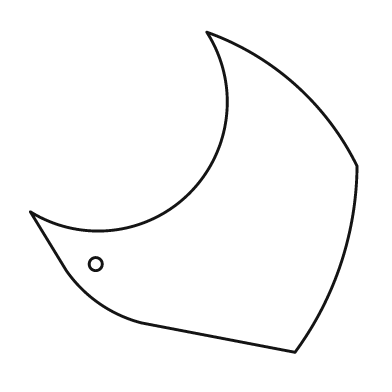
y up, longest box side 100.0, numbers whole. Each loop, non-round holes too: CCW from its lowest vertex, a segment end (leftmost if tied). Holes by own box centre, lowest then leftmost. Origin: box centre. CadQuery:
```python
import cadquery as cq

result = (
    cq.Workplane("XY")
    .moveTo(31.0, -49.0)
    .threePointArc((45.0, -22.0), (50.0, 8.0))
    .threePointArc((31.0, 33.0), (4.0, 49.0))
    .threePointArc((-1.0, 0.0), (-50.0, -6.0))
    .lineTo(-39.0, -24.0)
    .threePointArc((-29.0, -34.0), (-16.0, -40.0))
    .close()
    .moveTo(-30.0, -22.0)
    .circle(2.0)
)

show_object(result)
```